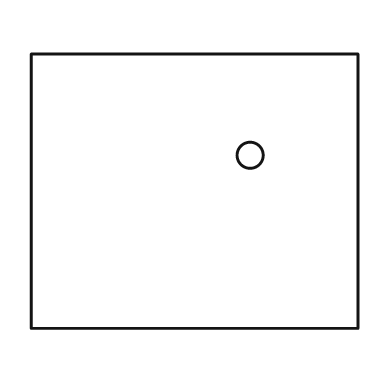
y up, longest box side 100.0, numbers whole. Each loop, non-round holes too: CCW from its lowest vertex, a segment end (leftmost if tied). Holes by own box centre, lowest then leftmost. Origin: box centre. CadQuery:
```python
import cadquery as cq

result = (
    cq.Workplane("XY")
    .moveTo(-50.0, -42.0)
    .lineTo(50.0, -42.0)
    .lineTo(50.0, 42.0)
    .lineTo(-50.0, 42.0)
    .close()
    .moveTo(17.0, 11.0)
    .circle(4.0)
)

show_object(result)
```